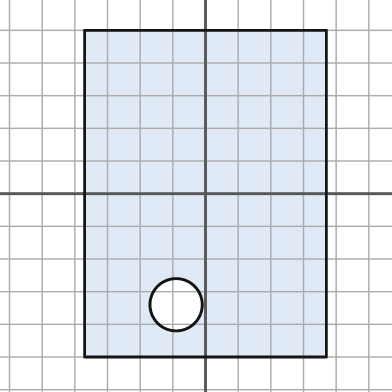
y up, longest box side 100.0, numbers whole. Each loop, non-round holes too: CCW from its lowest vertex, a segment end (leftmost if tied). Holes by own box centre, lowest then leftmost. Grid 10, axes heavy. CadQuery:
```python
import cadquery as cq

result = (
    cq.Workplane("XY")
    .moveTo(-37.0, -50.0)
    .lineTo(37.0, -50.0)
    .lineTo(37.0, 50.0)
    .lineTo(-37.0, 50.0)
    .close()
    .moveTo(-9.0, -34.0)
    .circle(8.0)
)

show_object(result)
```